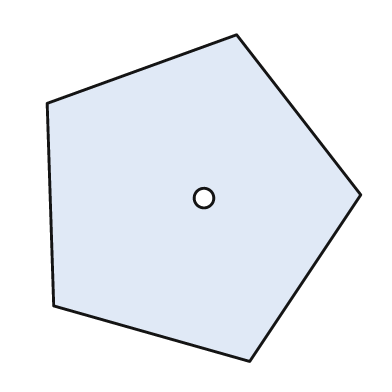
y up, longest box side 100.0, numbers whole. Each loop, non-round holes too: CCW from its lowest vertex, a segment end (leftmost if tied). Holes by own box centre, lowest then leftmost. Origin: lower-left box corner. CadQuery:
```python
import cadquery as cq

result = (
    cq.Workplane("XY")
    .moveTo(62.0, 0.0)
    .lineTo(96.0, 51.0)
    .lineTo(58.0, 100.0)
    .lineTo(0.0, 79.0)
    .lineTo(2.0, 17.0)
    .close()
    .moveTo(48.0, 50.0)
    .circle(3.0)
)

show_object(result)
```